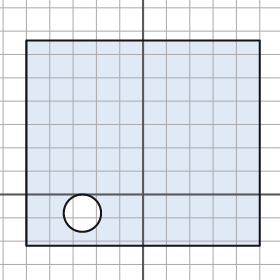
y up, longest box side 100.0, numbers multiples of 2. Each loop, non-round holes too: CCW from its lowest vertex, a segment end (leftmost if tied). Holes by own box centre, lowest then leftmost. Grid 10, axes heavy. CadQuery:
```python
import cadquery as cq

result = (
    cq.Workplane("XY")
    .moveTo(-50.0, -22.0)
    .lineTo(50.0, -22.0)
    .lineTo(50.0, 66.0)
    .lineTo(-50.0, 66.0)
    .close()
    .moveTo(-26.0, -8.0)
    .circle(8.0)
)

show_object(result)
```